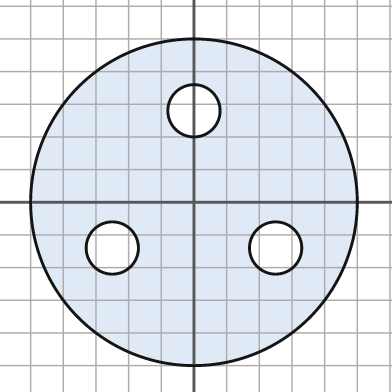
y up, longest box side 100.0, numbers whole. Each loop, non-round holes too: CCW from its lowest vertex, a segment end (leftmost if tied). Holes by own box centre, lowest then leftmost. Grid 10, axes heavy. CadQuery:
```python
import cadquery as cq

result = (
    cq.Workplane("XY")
    .moveTo(0.0, 0.0)
    .circle(50.0)
    .moveTo(-25.0, -14.0)
    .circle(8.0)
    .moveTo(25.0, -14.0)
    .circle(8.0)
    .moveTo(0.0, 28.0)
    .circle(8.0)
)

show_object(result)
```